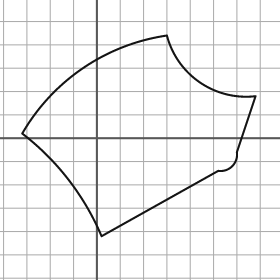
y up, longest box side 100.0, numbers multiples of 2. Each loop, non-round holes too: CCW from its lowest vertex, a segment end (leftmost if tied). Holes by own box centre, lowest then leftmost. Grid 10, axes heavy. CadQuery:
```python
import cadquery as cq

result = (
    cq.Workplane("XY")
    .moveTo(2.0, -42.0)
    .lineTo(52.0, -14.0)
    .threePointArc((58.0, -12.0), (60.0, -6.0))
    .lineTo(68.0, 18.0)
    .threePointArc((44.0, 24.0), (30.0, 44.0))
    .threePointArc((-6.0, 30.0), (-32.0, 2.0))
    .threePointArc((-12.0, -18.0), (2.0, -42.0))
    .close()
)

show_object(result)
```